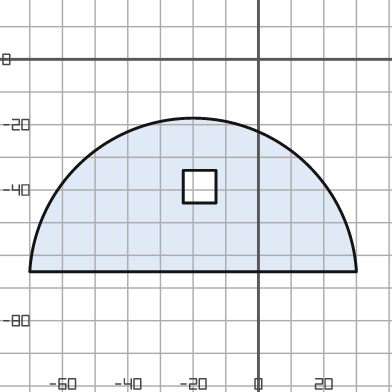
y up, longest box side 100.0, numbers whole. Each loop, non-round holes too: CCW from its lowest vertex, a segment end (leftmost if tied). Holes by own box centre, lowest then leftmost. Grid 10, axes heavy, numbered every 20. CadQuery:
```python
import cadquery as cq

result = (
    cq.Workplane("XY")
    .moveTo(-70.0, -65.0)
    .lineTo(30.0, -65.0)
    .threePointArc((-20.0, -18.0), (-70.0, -65.0))
    .close()
    .moveTo(-23.0, -44.0)
    .lineTo(-13.0, -44.0)
    .lineTo(-13.0, -34.0)
    .lineTo(-23.0, -34.0)
    .close()
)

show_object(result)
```